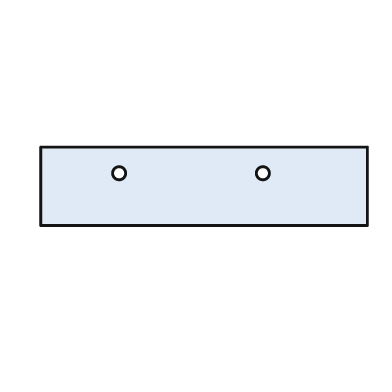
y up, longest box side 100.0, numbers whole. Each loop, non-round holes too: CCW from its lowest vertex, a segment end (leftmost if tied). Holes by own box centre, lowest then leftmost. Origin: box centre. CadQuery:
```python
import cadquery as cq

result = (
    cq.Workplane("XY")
    .moveTo(-50.0, -12.0)
    .lineTo(50.0, -12.0)
    .lineTo(50.0, 12.0)
    .lineTo(-50.0, 12.0)
    .close()
    .moveTo(-26.0, 4.0)
    .circle(2.0)
    .moveTo(18.0, 4.0)
    .circle(2.0)
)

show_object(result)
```